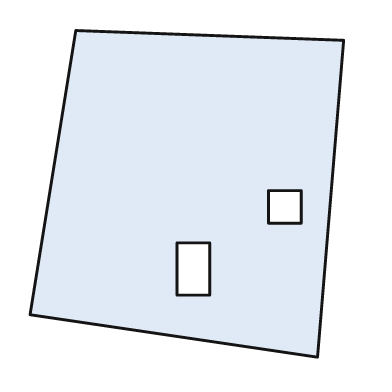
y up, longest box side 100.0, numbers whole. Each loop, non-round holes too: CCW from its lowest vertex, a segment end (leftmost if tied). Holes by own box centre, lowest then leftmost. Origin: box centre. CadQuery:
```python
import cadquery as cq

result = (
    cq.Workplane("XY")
    .moveTo(40.0, -50.0)
    .lineTo(48.0, 47.0)
    .lineTo(-34.0, 50.0)
    .lineTo(-48.0, -37.0)
    .close()
    .moveTo(-3.0, -31.0)
    .lineTo(7.0, -31.0)
    .lineTo(7.0, -15.0)
    .lineTo(-3.0, -15.0)
    .close()
    .moveTo(25.0, -9.0)
    .lineTo(35.0, -9.0)
    .lineTo(35.0, 1.0)
    .lineTo(25.0, 1.0)
    .close()
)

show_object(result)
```